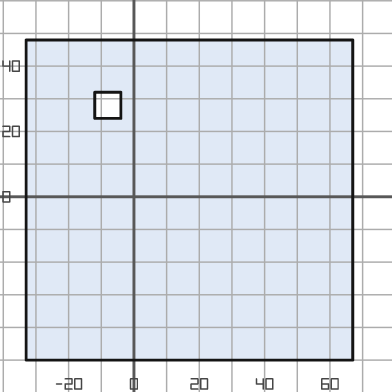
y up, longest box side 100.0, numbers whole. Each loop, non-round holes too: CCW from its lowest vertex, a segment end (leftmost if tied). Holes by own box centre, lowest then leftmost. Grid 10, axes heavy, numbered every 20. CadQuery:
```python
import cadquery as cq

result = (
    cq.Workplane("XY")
    .moveTo(-33.0, -50.0)
    .lineTo(67.0, -50.0)
    .lineTo(67.0, 48.0)
    .lineTo(-33.0, 48.0)
    .close()
    .moveTo(-12.0, 24.0)
    .lineTo(-4.0, 24.0)
    .lineTo(-4.0, 32.0)
    .lineTo(-12.0, 32.0)
    .close()
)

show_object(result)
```